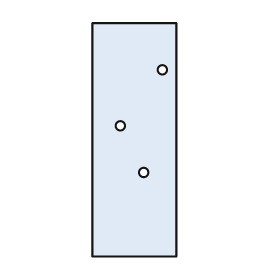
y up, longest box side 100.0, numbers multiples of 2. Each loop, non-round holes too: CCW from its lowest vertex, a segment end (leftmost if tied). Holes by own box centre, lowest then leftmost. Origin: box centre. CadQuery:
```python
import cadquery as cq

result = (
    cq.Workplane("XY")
    .moveTo(-18.0, -50.0)
    .lineTo(18.0, -50.0)
    .lineTo(18.0, 50.0)
    .lineTo(-18.0, 50.0)
    .close()
    .moveTo(4.0, -14.0)
    .circle(2.0)
    .moveTo(-6.0, 6.0)
    .circle(2.0)
    .moveTo(12.0, 30.0)
    .circle(2.0)
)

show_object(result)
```